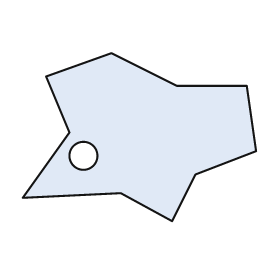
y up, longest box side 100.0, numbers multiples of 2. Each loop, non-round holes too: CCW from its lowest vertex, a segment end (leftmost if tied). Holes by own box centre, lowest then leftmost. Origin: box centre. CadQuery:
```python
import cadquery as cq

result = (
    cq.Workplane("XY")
    .moveTo(14.0, -36.0)
    .lineTo(24.0, -16.0)
    .lineTo(50.0, -6.0)
    .lineTo(46.0, 22.0)
    .lineTo(16.0, 22.0)
    .lineTo(-12.0, 36.0)
    .lineTo(-40.0, 26.0)
    .lineTo(-30.0, 2.0)
    .lineTo(-50.0, -26.0)
    .lineTo(-8.0, -24.0)
    .close()
    .moveTo(-24.0, -8.0)
    .circle(6.0)
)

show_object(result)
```